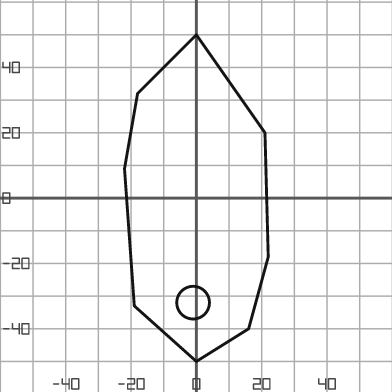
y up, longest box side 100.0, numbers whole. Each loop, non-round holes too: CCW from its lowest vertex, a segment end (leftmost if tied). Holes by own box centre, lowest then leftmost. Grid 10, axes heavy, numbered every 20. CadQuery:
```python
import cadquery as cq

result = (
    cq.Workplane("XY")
    .moveTo(0.0, -50.0)
    .lineTo(16.0, -40.0)
    .lineTo(22.0, -18.0)
    .lineTo(21.0, 20.0)
    .lineTo(0.0, 50.0)
    .lineTo(-18.0, 32.0)
    .lineTo(-22.0, 9.0)
    .lineTo(-19.0, -33.0)
    .close()
    .moveTo(-1.0, -32.0)
    .circle(5.0)
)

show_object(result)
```